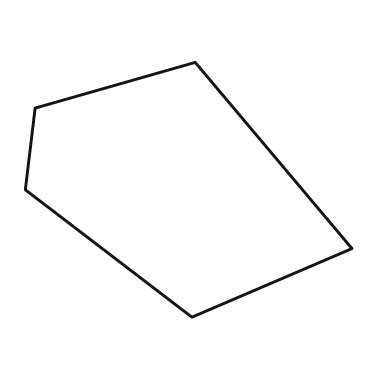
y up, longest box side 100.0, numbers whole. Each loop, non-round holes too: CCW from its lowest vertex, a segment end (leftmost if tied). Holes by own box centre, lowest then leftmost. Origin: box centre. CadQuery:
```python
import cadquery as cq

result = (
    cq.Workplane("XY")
    .moveTo(1.0, -39.0)
    .lineTo(50.0, -18.0)
    .lineTo(2.0, 39.0)
    .lineTo(-47.0, 25.0)
    .lineTo(-50.0, 0.0)
    .close()
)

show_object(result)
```